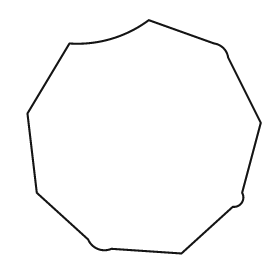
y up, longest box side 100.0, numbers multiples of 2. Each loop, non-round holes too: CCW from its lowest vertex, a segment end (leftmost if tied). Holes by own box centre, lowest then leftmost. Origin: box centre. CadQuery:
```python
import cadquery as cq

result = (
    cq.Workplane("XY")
    .moveTo(16.0, -50.0)
    .lineTo(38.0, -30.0)
    .threePointArc((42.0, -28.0), (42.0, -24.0))
    .lineTo(50.0, 6.0)
    .lineTo(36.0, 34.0)
    .threePointArc((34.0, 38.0), (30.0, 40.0))
    .lineTo(2.0, 50.0)
    .threePointArc((-14.0, 42.0), (-32.0, 40.0))
    .lineTo(-50.0, 10.0)
    .lineTo(-46.0, -24.0)
    .lineTo(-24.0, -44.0)
    .threePointArc((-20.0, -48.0), (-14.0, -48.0))
    .close()
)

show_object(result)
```